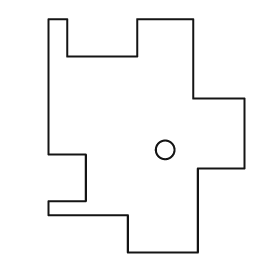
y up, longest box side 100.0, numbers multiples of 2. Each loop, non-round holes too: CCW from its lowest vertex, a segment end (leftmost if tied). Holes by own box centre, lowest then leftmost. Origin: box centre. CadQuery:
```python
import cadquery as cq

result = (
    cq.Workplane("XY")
    .moveTo(-8.0, -50.0)
    .lineTo(22.0, -50.0)
    .lineTo(22.0, -14.0)
    .lineTo(42.0, -14.0)
    .lineTo(42.0, 16.0)
    .lineTo(20.0, 16.0)
    .lineTo(20.0, 50.0)
    .lineTo(-4.0, 50.0)
    .lineTo(-4.0, 34.0)
    .lineTo(-34.0, 34.0)
    .lineTo(-34.0, 50.0)
    .lineTo(-42.0, 50.0)
    .lineTo(-42.0, -8.0)
    .lineTo(-26.0, -8.0)
    .lineTo(-26.0, -28.0)
    .lineTo(-42.0, -28.0)
    .lineTo(-42.0, -34.0)
    .lineTo(-8.0, -34.0)
    .close()
    .moveTo(8.0, -6.0)
    .circle(4.0)
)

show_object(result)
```